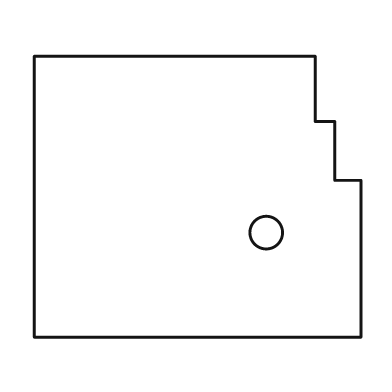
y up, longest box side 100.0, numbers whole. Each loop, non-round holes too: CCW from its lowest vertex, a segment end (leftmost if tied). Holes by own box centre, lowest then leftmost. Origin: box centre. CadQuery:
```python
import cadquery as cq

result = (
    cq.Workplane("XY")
    .moveTo(-50.0, -43.0)
    .lineTo(50.0, -43.0)
    .lineTo(50.0, 5.0)
    .lineTo(42.0, 5.0)
    .lineTo(42.0, 23.0)
    .lineTo(36.0, 23.0)
    .lineTo(36.0, 43.0)
    .lineTo(-50.0, 43.0)
    .close()
    .moveTo(21.0, -11.0)
    .circle(5.0)
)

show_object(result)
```